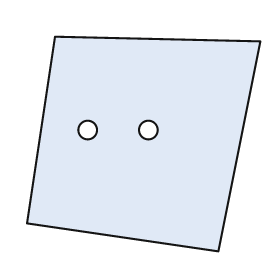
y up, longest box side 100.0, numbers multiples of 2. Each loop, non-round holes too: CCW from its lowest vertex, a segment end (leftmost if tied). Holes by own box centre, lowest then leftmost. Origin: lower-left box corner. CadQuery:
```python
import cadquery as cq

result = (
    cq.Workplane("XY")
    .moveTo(82.0, 0.0)
    .lineTo(100.0, 90.0)
    .lineTo(12.0, 92.0)
    .lineTo(0.0, 12.0)
    .close()
    .moveTo(26.0, 52.0)
    .circle(4.0)
    .moveTo(52.0, 52.0)
    .circle(4.0)
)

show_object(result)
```